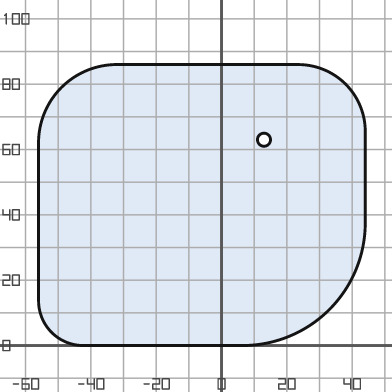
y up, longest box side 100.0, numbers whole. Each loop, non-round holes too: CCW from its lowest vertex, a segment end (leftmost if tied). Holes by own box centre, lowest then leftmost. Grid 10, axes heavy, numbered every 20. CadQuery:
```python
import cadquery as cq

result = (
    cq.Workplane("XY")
    .moveTo(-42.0, 0.0)
    .lineTo(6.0, 0.0)
    .threePointArc((33.0, 11.0), (44.0, 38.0))
    .lineTo(44.0, 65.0)
    .threePointArc((38.0, 80.0), (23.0, 86.0))
    .lineTo(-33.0, 86.0)
    .threePointArc((-49.0, 79.0), (-56.0, 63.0))
    .lineTo(-56.0, 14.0)
    .threePointArc((-52.0, 4.0), (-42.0, 0.0))
    .close()
    .moveTo(13.0, 63.0)
    .circle(2.0)
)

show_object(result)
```